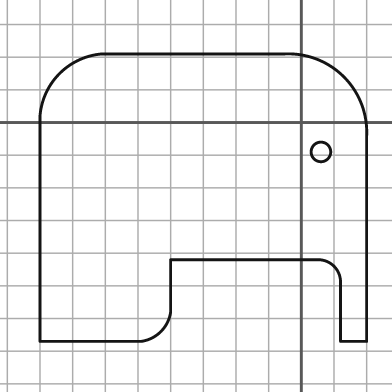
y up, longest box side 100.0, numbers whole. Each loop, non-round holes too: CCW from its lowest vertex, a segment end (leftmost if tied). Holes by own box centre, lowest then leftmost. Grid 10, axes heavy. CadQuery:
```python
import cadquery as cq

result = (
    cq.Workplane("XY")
    .moveTo(-80.0, -67.0)
    .lineTo(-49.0, -67.0)
    .threePointArc((-43.0, -64.0), (-40.0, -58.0))
    .lineTo(-40.0, -42.0)
    .lineTo(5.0, -42.0)
    .threePointArc((10.0, -44.0), (12.0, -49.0))
    .lineTo(12.0, -67.0)
    .lineTo(20.0, -67.0)
    .lineTo(20.0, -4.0)
    .threePointArc((13.0, 14.0), (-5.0, 21.0))
    .lineTo(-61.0, 21.0)
    .threePointArc((-74.0, 15.0), (-80.0, 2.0))
    .close()
    .moveTo(6.0, -9.0)
    .circle(3.0)
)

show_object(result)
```